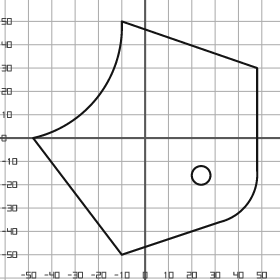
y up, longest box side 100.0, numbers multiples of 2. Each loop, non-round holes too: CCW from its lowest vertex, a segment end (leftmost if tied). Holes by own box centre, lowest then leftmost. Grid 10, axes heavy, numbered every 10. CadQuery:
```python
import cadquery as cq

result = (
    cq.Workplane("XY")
    .moveTo(-10.0, -50.0)
    .lineTo(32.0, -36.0)
    .threePointArc((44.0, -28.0), (48.0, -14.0))
    .lineTo(48.0, 30.0)
    .lineTo(-10.0, 50.0)
    .threePointArc((-20.0, 18.0), (-48.0, 0.0))
    .close()
    .moveTo(24.0, -16.0)
    .circle(4.0)
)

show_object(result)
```